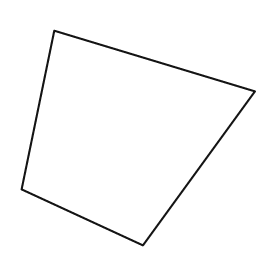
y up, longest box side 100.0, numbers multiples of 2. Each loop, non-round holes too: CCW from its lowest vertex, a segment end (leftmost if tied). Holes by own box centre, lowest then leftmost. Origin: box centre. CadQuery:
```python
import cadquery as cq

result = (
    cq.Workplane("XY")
    .moveTo(2.0, -46.0)
    .lineTo(50.0, 20.0)
    .lineTo(-36.0, 46.0)
    .lineTo(-50.0, -22.0)
    .close()
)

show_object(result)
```